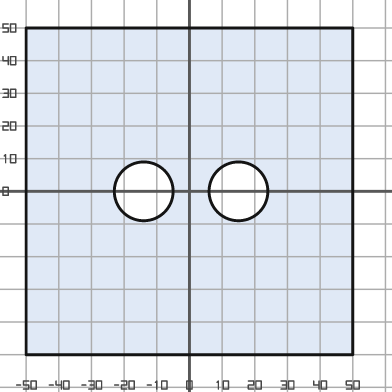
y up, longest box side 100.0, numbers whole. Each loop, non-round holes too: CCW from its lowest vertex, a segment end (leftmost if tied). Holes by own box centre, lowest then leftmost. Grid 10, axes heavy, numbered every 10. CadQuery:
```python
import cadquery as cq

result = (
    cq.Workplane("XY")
    .moveTo(-50.0, -50.0)
    .lineTo(50.0, -50.0)
    .lineTo(50.0, 50.0)
    .lineTo(-50.0, 50.0)
    .close()
    .moveTo(-14.0, 0.0)
    .circle(9.0)
    .moveTo(15.0, 0.0)
    .circle(9.0)
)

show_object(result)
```